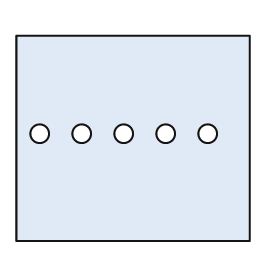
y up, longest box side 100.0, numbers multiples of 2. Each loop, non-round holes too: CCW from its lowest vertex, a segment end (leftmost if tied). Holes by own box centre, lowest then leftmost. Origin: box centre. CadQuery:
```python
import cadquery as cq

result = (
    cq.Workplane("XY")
    .moveTo(-50.0, -44.0)
    .lineTo(50.0, -44.0)
    .lineTo(50.0, 44.0)
    .lineTo(-50.0, 44.0)
    .close()
    .moveTo(-40.0, 2.0)
    .circle(4.0)
    .moveTo(-22.0, 2.0)
    .circle(4.0)
    .moveTo(-4.0, 2.0)
    .circle(4.0)
    .moveTo(14.0, 2.0)
    .circle(4.0)
    .moveTo(32.0, 2.0)
    .circle(4.0)
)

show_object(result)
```